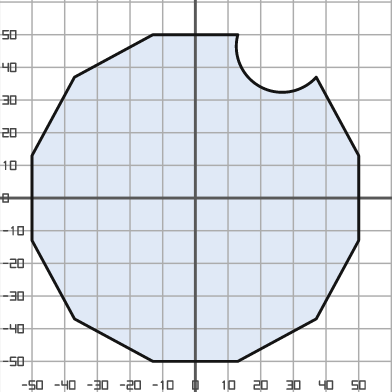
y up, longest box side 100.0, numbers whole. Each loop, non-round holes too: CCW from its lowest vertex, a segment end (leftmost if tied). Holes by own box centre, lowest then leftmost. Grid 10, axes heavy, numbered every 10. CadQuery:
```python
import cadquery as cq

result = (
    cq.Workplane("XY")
    .moveTo(-13.0, -50.0)
    .lineTo(13.0, -50.0)
    .lineTo(37.0, -37.0)
    .lineTo(50.0, -13.0)
    .lineTo(50.0, 13.0)
    .lineTo(37.0, 37.0)
    .threePointArc((20.0, 34.0), (13.0, 50.0))
    .lineTo(-13.0, 50.0)
    .lineTo(-37.0, 37.0)
    .lineTo(-50.0, 13.0)
    .lineTo(-50.0, -13.0)
    .lineTo(-37.0, -37.0)
    .close()
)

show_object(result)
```